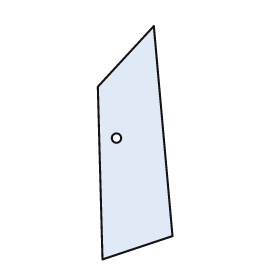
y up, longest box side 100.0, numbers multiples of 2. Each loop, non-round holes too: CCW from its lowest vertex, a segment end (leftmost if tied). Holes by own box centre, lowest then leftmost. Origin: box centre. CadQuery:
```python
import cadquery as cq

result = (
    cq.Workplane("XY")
    .moveTo(-14.0, -50.0)
    .lineTo(16.0, -40.0)
    .lineTo(8.0, 50.0)
    .lineTo(-16.0, 24.0)
    .close()
    .moveTo(-8.0, 2.0)
    .circle(2.0)
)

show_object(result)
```